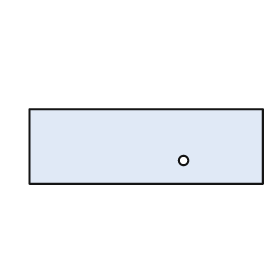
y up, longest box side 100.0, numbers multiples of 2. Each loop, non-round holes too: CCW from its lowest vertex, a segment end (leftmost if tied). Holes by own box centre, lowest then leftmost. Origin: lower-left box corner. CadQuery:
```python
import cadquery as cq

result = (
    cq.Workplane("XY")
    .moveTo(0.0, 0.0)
    .lineTo(100.0, 0.0)
    .lineTo(100.0, 32.0)
    .lineTo(0.0, 32.0)
    .close()
    .moveTo(66.0, 10.0)
    .circle(2.0)
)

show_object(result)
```